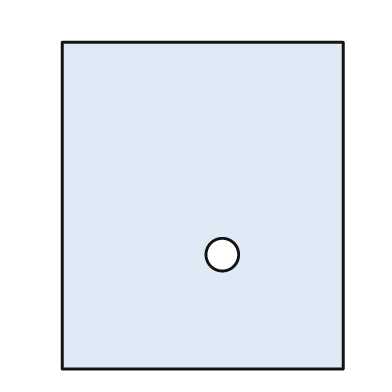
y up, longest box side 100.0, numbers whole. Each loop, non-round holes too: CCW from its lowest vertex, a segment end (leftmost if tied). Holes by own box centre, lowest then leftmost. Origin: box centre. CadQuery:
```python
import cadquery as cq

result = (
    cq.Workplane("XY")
    .moveTo(-43.0, -50.0)
    .lineTo(43.0, -50.0)
    .lineTo(43.0, 50.0)
    .lineTo(-43.0, 50.0)
    .close()
    .moveTo(6.0, -15.0)
    .circle(5.0)
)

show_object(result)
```